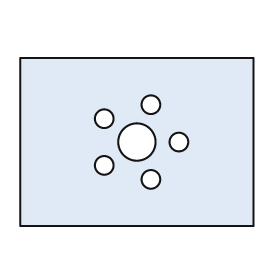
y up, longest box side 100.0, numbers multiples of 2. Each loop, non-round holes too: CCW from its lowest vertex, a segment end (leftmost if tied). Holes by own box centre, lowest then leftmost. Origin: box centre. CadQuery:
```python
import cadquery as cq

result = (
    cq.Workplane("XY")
    .moveTo(-50.0, -36.0)
    .lineTo(50.0, -36.0)
    .lineTo(50.0, 36.0)
    .lineTo(-50.0, 36.0)
    .close()
    .moveTo(6.0, -16.0)
    .circle(4.0)
    .moveTo(-14.0, -10.0)
    .circle(4.0)
    .moveTo(0.0, 0.0)
    .circle(8.0)
    .moveTo(18.0, 0.0)
    .circle(4.0)
    .moveTo(-14.0, 10.0)
    .circle(4.0)
    .moveTo(6.0, 16.0)
    .circle(4.0)
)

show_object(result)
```